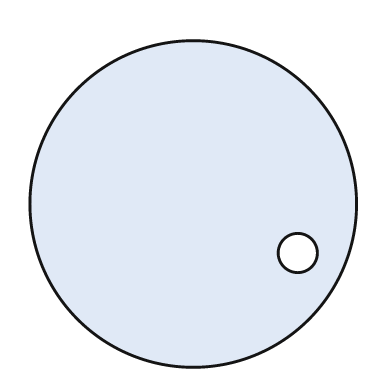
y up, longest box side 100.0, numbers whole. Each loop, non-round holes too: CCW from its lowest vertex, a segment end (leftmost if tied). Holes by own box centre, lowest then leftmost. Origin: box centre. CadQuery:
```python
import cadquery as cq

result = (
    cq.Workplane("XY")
    .moveTo(0.0, 0.0)
    .circle(50.0)
    .moveTo(32.0, -15.0)
    .circle(6.0)
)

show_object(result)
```